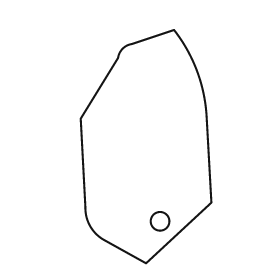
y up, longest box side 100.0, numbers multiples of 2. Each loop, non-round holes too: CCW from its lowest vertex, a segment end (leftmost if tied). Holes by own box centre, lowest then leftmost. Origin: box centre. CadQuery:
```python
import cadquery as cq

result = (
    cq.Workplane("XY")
    .moveTo(0.0, -50.0)
    .lineTo(28.0, -24.0)
    .lineTo(26.0, 12.0)
    .threePointArc((22.0, 32.0), (12.0, 50.0))
    .lineTo(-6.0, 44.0)
    .threePointArc((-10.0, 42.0), (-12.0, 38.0))
    .lineTo(-28.0, 12.0)
    .lineTo(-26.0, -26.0)
    .threePointArc((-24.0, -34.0), (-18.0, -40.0))
    .close()
    .moveTo(6.0, -32.0)
    .circle(4.0)
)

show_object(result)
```